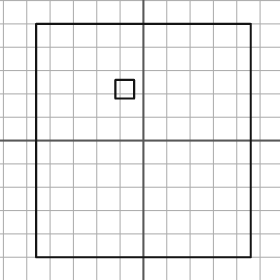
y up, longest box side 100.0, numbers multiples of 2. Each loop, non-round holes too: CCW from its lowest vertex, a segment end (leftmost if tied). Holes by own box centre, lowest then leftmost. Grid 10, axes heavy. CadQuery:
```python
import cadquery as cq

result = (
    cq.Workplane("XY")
    .moveTo(-46.0, -50.0)
    .lineTo(46.0, -50.0)
    .lineTo(46.0, 50.0)
    .lineTo(-46.0, 50.0)
    .close()
    .moveTo(-12.0, 18.0)
    .lineTo(-4.0, 18.0)
    .lineTo(-4.0, 26.0)
    .lineTo(-12.0, 26.0)
    .close()
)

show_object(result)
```